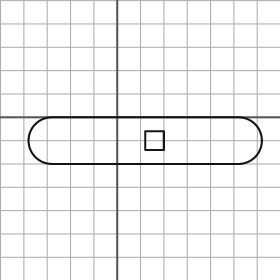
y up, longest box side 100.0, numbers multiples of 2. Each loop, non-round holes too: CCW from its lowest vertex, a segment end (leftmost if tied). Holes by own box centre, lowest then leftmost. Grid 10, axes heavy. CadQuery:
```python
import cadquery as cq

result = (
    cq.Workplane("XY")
    .moveTo(-28.0, -20.0)
    .lineTo(52.0, -20.0)
    .threePointArc((62.0, -10.0), (52.0, 0.0))
    .lineTo(-28.0, 0.0)
    .threePointArc((-38.0, -10.0), (-28.0, -20.0))
    .close()
    .moveTo(12.0, -14.0)
    .lineTo(20.0, -14.0)
    .lineTo(20.0, -6.0)
    .lineTo(12.0, -6.0)
    .close()
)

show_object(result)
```